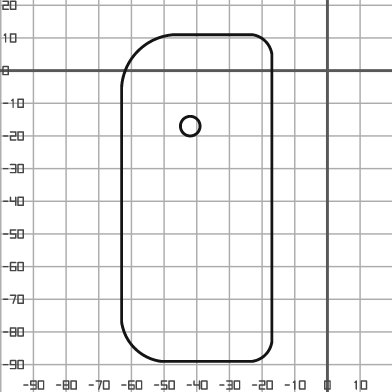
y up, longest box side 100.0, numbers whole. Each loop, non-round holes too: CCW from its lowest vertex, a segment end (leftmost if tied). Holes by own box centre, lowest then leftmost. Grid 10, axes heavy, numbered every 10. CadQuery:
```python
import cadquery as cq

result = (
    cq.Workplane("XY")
    .moveTo(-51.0, -89.0)
    .lineTo(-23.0, -89.0)
    .threePointArc((-19.0, -87.0), (-17.0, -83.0))
    .lineTo(-17.0, 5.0)
    .threePointArc((-19.0, 9.0), (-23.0, 11.0))
    .lineTo(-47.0, 11.0)
    .threePointArc((-58.0, 6.0), (-63.0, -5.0))
    .lineTo(-63.0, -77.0)
    .threePointArc((-59.0, -85.0), (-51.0, -89.0))
    .close()
    .moveTo(-42.0, -17.0)
    .circle(3.0)
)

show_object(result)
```